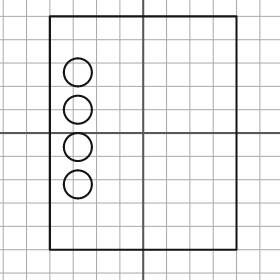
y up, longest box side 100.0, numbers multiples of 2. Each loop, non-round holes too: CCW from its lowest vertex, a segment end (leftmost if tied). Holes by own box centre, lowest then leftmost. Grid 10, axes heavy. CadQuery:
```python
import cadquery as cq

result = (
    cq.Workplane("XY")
    .moveTo(-40.0, -50.0)
    .lineTo(40.0, -50.0)
    .lineTo(40.0, 50.0)
    .lineTo(-40.0, 50.0)
    .close()
    .moveTo(-28.0, -22.0)
    .circle(6.0)
    .moveTo(-28.0, -6.0)
    .circle(6.0)
    .moveTo(-28.0, 10.0)
    .circle(6.0)
    .moveTo(-28.0, 26.0)
    .circle(6.0)
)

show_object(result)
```